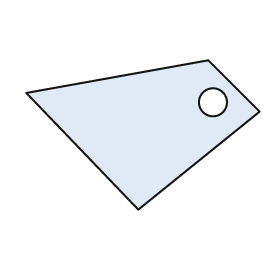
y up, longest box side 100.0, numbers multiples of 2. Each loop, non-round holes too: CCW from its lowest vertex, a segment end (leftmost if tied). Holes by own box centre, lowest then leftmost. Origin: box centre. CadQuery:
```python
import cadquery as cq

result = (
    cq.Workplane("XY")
    .moveTo(-2.0, -32.0)
    .lineTo(50.0, 10.0)
    .lineTo(28.0, 32.0)
    .lineTo(-50.0, 18.0)
    .close()
    .moveTo(30.0, 14.0)
    .circle(6.0)
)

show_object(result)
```